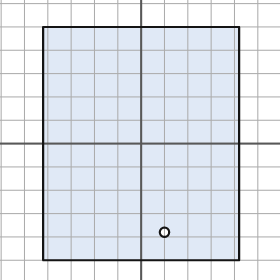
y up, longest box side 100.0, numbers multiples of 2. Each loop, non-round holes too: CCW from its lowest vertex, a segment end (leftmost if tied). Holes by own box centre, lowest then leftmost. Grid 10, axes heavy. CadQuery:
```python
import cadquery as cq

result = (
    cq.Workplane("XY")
    .moveTo(-42.0, -50.0)
    .lineTo(42.0, -50.0)
    .lineTo(42.0, 50.0)
    .lineTo(-42.0, 50.0)
    .close()
    .moveTo(10.0, -38.0)
    .circle(2.0)
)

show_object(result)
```